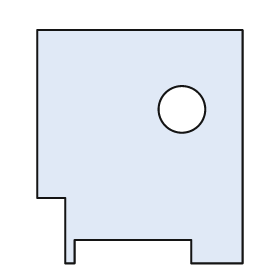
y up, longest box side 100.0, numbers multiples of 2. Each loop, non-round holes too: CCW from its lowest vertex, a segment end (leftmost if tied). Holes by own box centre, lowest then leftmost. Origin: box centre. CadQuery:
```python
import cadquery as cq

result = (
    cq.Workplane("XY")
    .moveTo(-32.0, -50.0)
    .lineTo(-28.0, -50.0)
    .lineTo(-28.0, -40.0)
    .lineTo(22.0, -40.0)
    .lineTo(22.0, -50.0)
    .lineTo(44.0, -50.0)
    .lineTo(44.0, 50.0)
    .lineTo(-44.0, 50.0)
    .lineTo(-44.0, -22.0)
    .lineTo(-32.0, -22.0)
    .close()
    .moveTo(18.0, 16.0)
    .circle(10.0)
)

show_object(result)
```